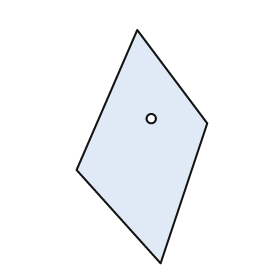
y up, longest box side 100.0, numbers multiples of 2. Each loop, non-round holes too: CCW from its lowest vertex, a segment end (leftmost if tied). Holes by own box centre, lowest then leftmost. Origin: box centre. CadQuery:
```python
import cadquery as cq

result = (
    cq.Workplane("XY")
    .moveTo(8.0, -50.0)
    .lineTo(28.0, 10.0)
    .lineTo(-2.0, 50.0)
    .lineTo(-28.0, -10.0)
    .close()
    .moveTo(4.0, 12.0)
    .circle(2.0)
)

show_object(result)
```